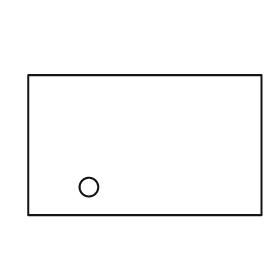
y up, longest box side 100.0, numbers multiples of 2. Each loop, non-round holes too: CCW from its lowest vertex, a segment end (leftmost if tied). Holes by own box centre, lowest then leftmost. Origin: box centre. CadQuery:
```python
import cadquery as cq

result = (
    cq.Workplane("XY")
    .moveTo(-50.0, -30.0)
    .lineTo(50.0, -30.0)
    .lineTo(50.0, 30.0)
    .lineTo(-50.0, 30.0)
    .close()
    .moveTo(-24.0, -18.0)
    .circle(4.0)
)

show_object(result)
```